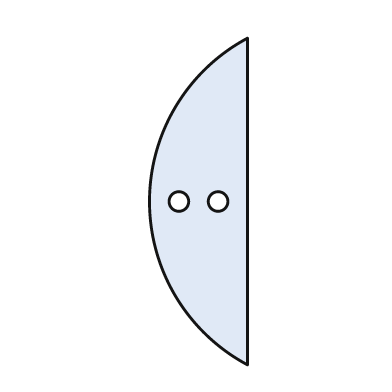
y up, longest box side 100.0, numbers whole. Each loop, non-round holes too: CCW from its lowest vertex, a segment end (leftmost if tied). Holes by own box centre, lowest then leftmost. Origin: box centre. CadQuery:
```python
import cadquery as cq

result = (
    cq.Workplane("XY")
    .moveTo(15.0, -50.0)
    .lineTo(15.0, 50.0)
    .threePointArc((-15.0, 0.0), (15.0, -50.0))
    .close()
    .moveTo(-6.0, 0.0)
    .circle(3.0)
    .moveTo(6.0, 0.0)
    .circle(3.0)
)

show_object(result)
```